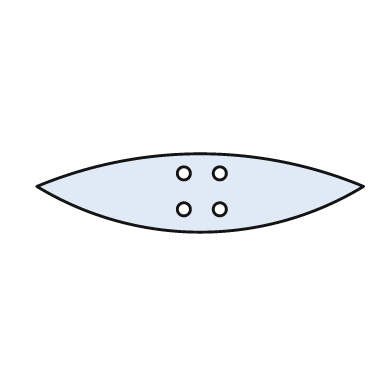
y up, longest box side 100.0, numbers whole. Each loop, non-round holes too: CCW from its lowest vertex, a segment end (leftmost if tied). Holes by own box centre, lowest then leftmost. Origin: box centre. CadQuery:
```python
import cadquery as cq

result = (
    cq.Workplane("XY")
    .moveTo(-50.0, 2.0)
    .threePointArc((0.0, -12.0), (50.0, 2.0))
    .threePointArc((0.0, 12.0), (-50.0, 2.0))
    .close()
    .moveTo(-5.0, -5.0)
    .circle(2.0)
    .moveTo(6.0, -5.0)
    .circle(2.0)
    .moveTo(-5.0, 6.0)
    .circle(2.0)
    .moveTo(6.0, 6.0)
    .circle(2.0)
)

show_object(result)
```